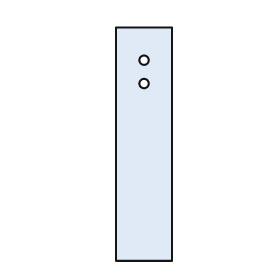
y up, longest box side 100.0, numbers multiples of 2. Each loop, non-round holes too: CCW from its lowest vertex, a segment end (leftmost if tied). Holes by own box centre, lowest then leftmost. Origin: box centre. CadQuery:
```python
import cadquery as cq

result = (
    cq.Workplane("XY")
    .moveTo(-12.0, -50.0)
    .lineTo(12.0, -50.0)
    .lineTo(12.0, 50.0)
    .lineTo(-12.0, 50.0)
    .close()
    .moveTo(0.0, 26.0)
    .circle(2.0)
    .moveTo(0.0, 36.0)
    .circle(2.0)
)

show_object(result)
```